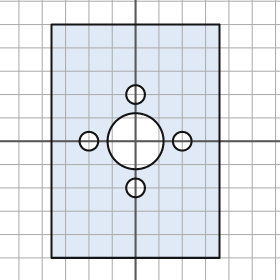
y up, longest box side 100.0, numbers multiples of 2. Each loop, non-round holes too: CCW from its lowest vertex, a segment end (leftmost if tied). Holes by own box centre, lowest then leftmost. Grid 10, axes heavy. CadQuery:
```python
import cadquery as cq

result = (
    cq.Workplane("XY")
    .moveTo(-36.0, -50.0)
    .lineTo(36.0, -50.0)
    .lineTo(36.0, 50.0)
    .lineTo(-36.0, 50.0)
    .close()
    .moveTo(0.0, -20.0)
    .circle(4.0)
    .moveTo(-20.0, 0.0)
    .circle(4.0)
    .moveTo(0.0, 0.0)
    .circle(12.0)
    .moveTo(20.0, 0.0)
    .circle(4.0)
    .moveTo(0.0, 20.0)
    .circle(4.0)
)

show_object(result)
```